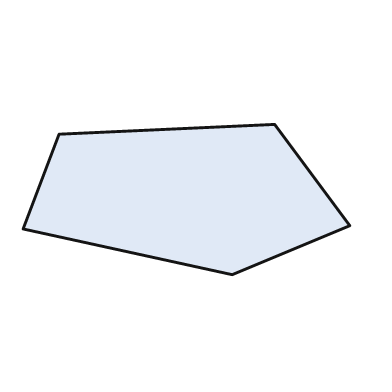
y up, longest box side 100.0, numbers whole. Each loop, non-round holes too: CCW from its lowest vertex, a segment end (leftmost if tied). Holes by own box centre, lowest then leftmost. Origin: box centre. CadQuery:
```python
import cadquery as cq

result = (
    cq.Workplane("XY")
    .moveTo(14.0, -23.0)
    .lineTo(50.0, -8.0)
    .lineTo(27.0, 23.0)
    .lineTo(-39.0, 20.0)
    .lineTo(-50.0, -9.0)
    .close()
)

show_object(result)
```